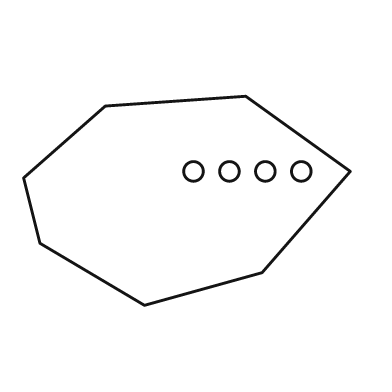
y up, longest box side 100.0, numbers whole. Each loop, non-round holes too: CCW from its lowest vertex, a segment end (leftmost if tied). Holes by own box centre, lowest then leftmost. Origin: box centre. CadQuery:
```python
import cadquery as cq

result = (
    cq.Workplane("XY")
    .moveTo(-13.0, -32.0)
    .lineTo(23.0, -22.0)
    .lineTo(50.0, 9.0)
    .lineTo(18.0, 32.0)
    .lineTo(-25.0, 29.0)
    .lineTo(-50.0, 7.0)
    .lineTo(-45.0, -13.0)
    .close()
    .moveTo(2.0, 9.0)
    .circle(3.0)
    .moveTo(13.0, 9.0)
    .circle(3.0)
    .moveTo(24.0, 9.0)
    .circle(3.0)
    .moveTo(35.0, 9.0)
    .circle(3.0)
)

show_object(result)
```